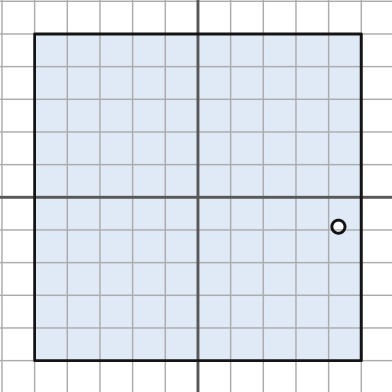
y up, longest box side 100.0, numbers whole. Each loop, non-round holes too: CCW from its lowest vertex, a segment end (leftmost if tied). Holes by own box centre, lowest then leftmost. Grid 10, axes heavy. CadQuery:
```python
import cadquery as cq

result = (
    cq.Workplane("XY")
    .moveTo(-50.0, -50.0)
    .lineTo(50.0, -50.0)
    .lineTo(50.0, 50.0)
    .lineTo(-50.0, 50.0)
    .close()
    .moveTo(43.0, -9.0)
    .circle(2.0)
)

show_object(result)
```